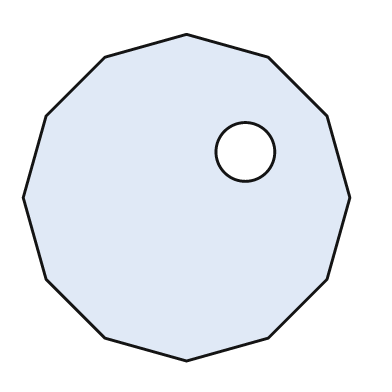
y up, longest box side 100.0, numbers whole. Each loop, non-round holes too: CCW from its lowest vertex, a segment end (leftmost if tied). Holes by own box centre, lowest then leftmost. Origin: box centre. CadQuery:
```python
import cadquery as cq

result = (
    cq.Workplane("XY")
    .moveTo(0.0, -50.0)
    .lineTo(25.0, -43.0)
    .lineTo(43.0, -25.0)
    .lineTo(50.0, 0.0)
    .lineTo(43.0, 25.0)
    .lineTo(25.0, 43.0)
    .lineTo(0.0, 50.0)
    .lineTo(-25.0, 43.0)
    .lineTo(-43.0, 25.0)
    .lineTo(-50.0, 0.0)
    .lineTo(-43.0, -25.0)
    .lineTo(-25.0, -43.0)
    .close()
    .moveTo(18.0, 14.0)
    .circle(9.0)
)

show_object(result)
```